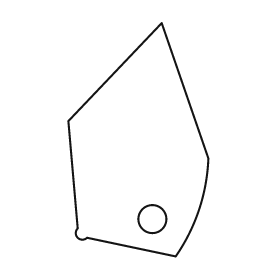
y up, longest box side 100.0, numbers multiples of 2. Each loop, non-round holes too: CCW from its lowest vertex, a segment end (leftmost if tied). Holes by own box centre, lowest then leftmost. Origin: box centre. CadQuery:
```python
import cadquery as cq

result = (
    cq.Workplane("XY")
    .moveTo(16.0, -50.0)
    .threePointArc((26.0, -30.0), (30.0, -8.0))
    .lineTo(10.0, 50.0)
    .lineTo(-30.0, 8.0)
    .lineTo(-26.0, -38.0)
    .threePointArc((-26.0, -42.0), (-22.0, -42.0))
    .close()
    .moveTo(6.0, -34.0)
    .circle(6.0)
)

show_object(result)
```